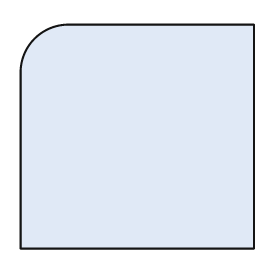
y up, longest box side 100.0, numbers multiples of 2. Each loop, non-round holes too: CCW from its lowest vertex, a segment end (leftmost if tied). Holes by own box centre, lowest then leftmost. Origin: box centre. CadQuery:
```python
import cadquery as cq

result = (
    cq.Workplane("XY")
    .moveTo(-50.0, -48.0)
    .lineTo(50.0, -48.0)
    .lineTo(50.0, 48.0)
    .lineTo(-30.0, 48.0)
    .threePointArc((-44.0, 42.0), (-50.0, 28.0))
    .close()
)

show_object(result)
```